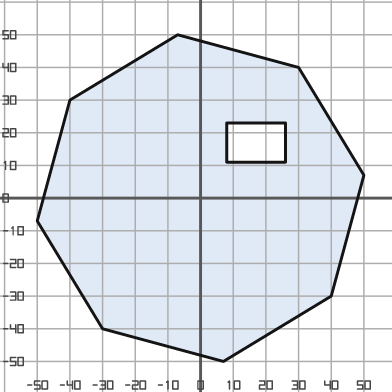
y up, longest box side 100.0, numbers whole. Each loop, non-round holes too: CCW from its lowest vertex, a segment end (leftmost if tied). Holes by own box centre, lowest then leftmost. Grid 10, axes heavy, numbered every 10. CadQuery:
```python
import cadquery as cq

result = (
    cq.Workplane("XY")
    .moveTo(7.0, -50.0)
    .lineTo(40.0, -30.0)
    .lineTo(50.0, 7.0)
    .lineTo(30.0, 40.0)
    .lineTo(-7.0, 50.0)
    .lineTo(-40.0, 30.0)
    .lineTo(-50.0, -7.0)
    .lineTo(-30.0, -40.0)
    .close()
    .moveTo(8.0, 11.0)
    .lineTo(26.0, 11.0)
    .lineTo(26.0, 23.0)
    .lineTo(8.0, 23.0)
    .close()
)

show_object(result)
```